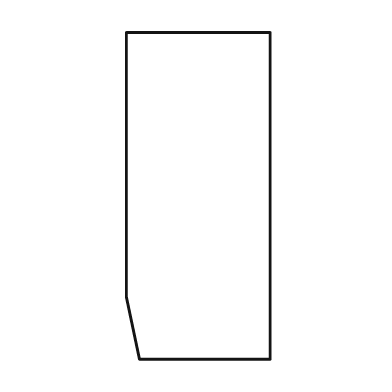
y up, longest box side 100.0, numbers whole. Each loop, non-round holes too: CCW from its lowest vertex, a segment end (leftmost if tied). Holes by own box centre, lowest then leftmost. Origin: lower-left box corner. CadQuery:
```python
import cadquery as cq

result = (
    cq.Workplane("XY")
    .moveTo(4.0, 0.0)
    .lineTo(44.0, 0.0)
    .lineTo(44.0, 100.0)
    .lineTo(0.0, 100.0)
    .lineTo(0.0, 19.0)
    .close()
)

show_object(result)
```